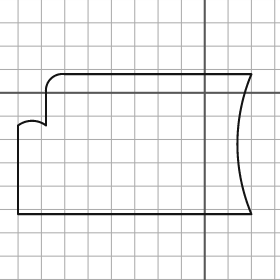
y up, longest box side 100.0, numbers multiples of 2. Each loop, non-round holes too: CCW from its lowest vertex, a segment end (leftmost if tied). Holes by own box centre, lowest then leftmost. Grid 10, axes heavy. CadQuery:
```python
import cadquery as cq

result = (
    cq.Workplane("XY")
    .moveTo(-80.0, -52.0)
    .lineTo(20.0, -52.0)
    .threePointArc((14.0, -22.0), (20.0, 8.0))
    .lineTo(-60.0, 8.0)
    .threePointArc((-66.0, 6.0), (-68.0, 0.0))
    .lineTo(-68.0, -14.0)
    .threePointArc((-74.0, -12.0), (-80.0, -14.0))
    .close()
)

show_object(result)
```